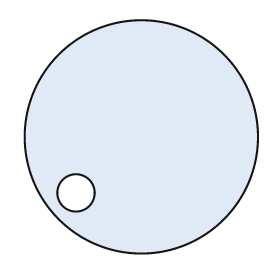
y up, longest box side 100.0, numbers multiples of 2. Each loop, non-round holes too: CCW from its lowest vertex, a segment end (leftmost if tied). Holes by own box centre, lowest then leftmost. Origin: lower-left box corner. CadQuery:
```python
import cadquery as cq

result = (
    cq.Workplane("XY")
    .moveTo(50.0, 50.0)
    .circle(50.0)
    .moveTo(22.0, 26.0)
    .circle(8.0)
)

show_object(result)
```